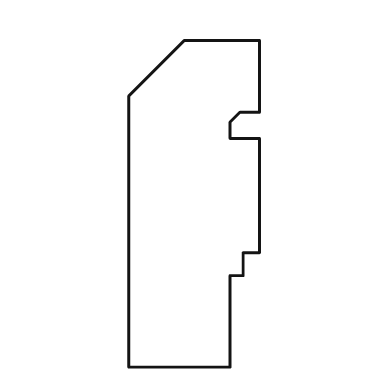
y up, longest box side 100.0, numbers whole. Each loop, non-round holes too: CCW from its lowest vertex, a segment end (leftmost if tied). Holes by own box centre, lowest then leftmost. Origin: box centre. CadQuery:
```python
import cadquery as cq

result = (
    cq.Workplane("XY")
    .moveTo(-20.0, -50.0)
    .lineTo(11.0, -50.0)
    .lineTo(11.0, -22.0)
    .lineTo(15.0, -22.0)
    .lineTo(15.0, -15.0)
    .lineTo(20.0, -15.0)
    .lineTo(20.0, 20.0)
    .lineTo(11.0, 20.0)
    .lineTo(11.0, 25.0)
    .lineTo(14.0, 28.0)
    .lineTo(20.0, 28.0)
    .lineTo(20.0, 50.0)
    .lineTo(-3.0, 50.0)
    .lineTo(-20.0, 33.0)
    .close()
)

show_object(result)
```